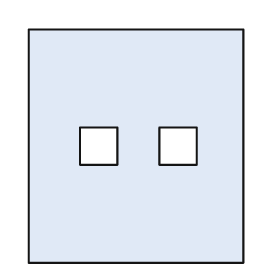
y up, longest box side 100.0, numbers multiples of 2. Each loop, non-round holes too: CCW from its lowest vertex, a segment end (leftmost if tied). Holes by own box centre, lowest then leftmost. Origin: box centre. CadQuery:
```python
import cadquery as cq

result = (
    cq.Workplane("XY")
    .moveTo(-46.0, -50.0)
    .lineTo(46.0, -50.0)
    .lineTo(46.0, 50.0)
    .lineTo(-46.0, 50.0)
    .close()
    .moveTo(-24.0, -8.0)
    .lineTo(-8.0, -8.0)
    .lineTo(-8.0, 8.0)
    .lineTo(-24.0, 8.0)
    .close()
    .moveTo(10.0, -8.0)
    .lineTo(26.0, -8.0)
    .lineTo(26.0, 8.0)
    .lineTo(10.0, 8.0)
    .close()
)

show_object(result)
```